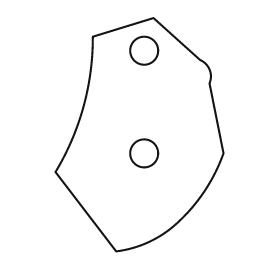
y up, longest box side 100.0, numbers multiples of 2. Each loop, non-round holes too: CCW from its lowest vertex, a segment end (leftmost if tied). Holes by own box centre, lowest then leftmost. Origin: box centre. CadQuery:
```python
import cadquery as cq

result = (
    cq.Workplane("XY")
    .moveTo(-10.0, -50.0)
    .threePointArc((4.0, -46.0), (16.0, -38.0))
    .threePointArc((28.0, -24.0), (36.0, -8.0))
    .lineTo(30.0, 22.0)
    .threePointArc((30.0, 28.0), (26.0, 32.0))
    .lineTo(6.0, 50.0)
    .lineTo(-20.0, 42.0)
    .threePointArc((-24.0, 12.0), (-36.0, -16.0))
    .close()
    .moveTo(2.0, -8.0)
    .circle(6.0)
    .moveTo(2.0, 36.0)
    .circle(6.0)
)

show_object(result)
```